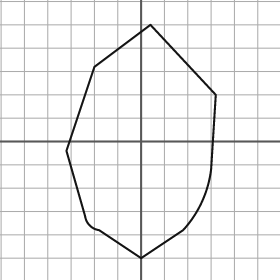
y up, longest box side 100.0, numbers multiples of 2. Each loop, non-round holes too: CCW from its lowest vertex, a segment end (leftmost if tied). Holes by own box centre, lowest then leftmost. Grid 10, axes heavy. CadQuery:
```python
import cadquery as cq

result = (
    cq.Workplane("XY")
    .moveTo(0.0, -50.0)
    .lineTo(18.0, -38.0)
    .threePointArc((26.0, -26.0), (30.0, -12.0))
    .lineTo(32.0, 20.0)
    .lineTo(4.0, 50.0)
    .lineTo(-20.0, 32.0)
    .lineTo(-32.0, -4.0)
    .lineTo(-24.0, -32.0)
    .threePointArc((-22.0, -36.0), (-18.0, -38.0))
    .close()
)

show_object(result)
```